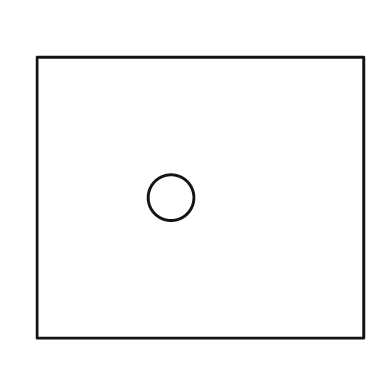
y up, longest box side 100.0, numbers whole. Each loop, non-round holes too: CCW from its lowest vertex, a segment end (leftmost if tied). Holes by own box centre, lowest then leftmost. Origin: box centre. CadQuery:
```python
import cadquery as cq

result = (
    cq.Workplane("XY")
    .moveTo(-50.0, -43.0)
    .lineTo(50.0, -43.0)
    .lineTo(50.0, 43.0)
    .lineTo(-50.0, 43.0)
    .close()
    .moveTo(-9.0, 0.0)
    .circle(7.0)
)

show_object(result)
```